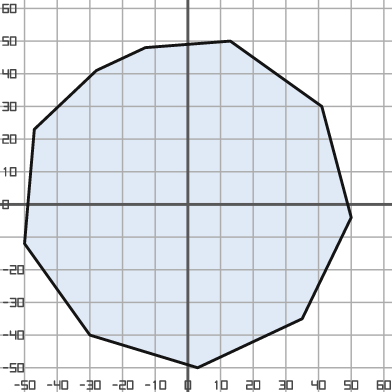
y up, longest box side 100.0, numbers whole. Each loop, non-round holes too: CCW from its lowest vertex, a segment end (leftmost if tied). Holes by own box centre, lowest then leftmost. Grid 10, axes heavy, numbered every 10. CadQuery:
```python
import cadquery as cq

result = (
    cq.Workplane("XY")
    .moveTo(3.0, -50.0)
    .lineTo(35.0, -35.0)
    .lineTo(50.0, -4.0)
    .lineTo(41.0, 30.0)
    .lineTo(13.0, 50.0)
    .lineTo(-13.0, 48.0)
    .lineTo(-28.0, 41.0)
    .lineTo(-47.0, 23.0)
    .lineTo(-50.0, -12.0)
    .lineTo(-30.0, -40.0)
    .close()
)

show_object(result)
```